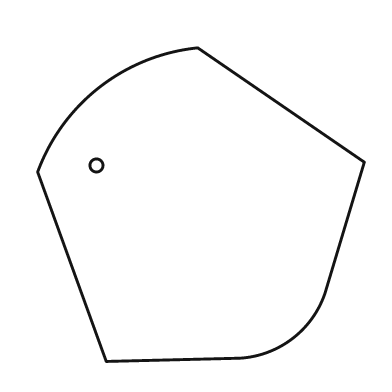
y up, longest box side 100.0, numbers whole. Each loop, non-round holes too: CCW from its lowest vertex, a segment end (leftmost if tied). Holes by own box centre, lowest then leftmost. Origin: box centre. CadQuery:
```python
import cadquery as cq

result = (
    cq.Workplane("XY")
    .moveTo(-29.0, -48.0)
    .lineTo(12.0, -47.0)
    .threePointArc((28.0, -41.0), (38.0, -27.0))
    .lineTo(50.0, 13.0)
    .lineTo(-1.0, 48.0)
    .threePointArc((-31.0, 36.0), (-50.0, 10.0))
    .close()
    .moveTo(-32.0, 12.0)
    .circle(2.0)
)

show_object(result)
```